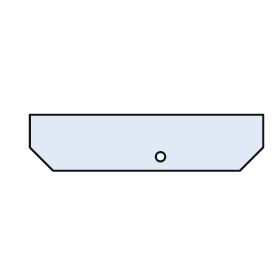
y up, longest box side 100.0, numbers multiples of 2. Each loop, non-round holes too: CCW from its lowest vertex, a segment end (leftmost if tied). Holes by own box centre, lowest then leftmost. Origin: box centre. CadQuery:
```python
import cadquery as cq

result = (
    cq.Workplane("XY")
    .moveTo(-40.0, -12.0)
    .lineTo(40.0, -12.0)
    .lineTo(50.0, -2.0)
    .lineTo(50.0, 12.0)
    .lineTo(-50.0, 12.0)
    .lineTo(-50.0, -2.0)
    .close()
    .moveTo(6.0, -6.0)
    .circle(2.0)
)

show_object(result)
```